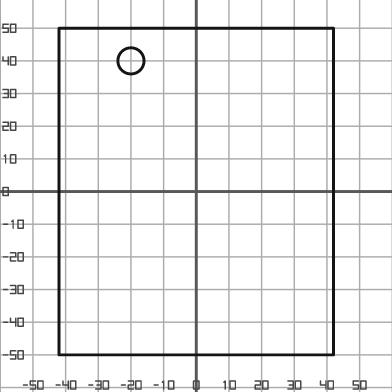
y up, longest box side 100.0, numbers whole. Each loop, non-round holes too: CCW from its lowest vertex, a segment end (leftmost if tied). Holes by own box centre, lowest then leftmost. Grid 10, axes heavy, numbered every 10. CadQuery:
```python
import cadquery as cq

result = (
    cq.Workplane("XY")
    .moveTo(-42.0, -50.0)
    .lineTo(42.0, -50.0)
    .lineTo(42.0, 50.0)
    .lineTo(-42.0, 50.0)
    .close()
    .moveTo(-20.0, 40.0)
    .circle(4.0)
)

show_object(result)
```